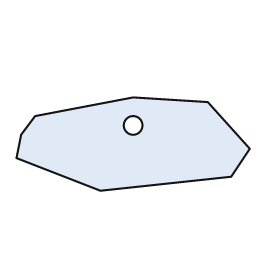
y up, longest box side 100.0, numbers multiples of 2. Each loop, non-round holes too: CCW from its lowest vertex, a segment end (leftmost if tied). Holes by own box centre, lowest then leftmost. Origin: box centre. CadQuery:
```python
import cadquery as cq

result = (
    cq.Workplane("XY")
    .moveTo(-14.0, -20.0)
    .lineTo(42.0, -14.0)
    .lineTo(50.0, -2.0)
    .lineTo(32.0, 18.0)
    .lineTo(0.0, 20.0)
    .lineTo(-42.0, 12.0)
    .lineTo(-48.0, 4.0)
    .lineTo(-50.0, -6.0)
    .close()
    .moveTo(0.0, 8.0)
    .circle(4.0)
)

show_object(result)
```